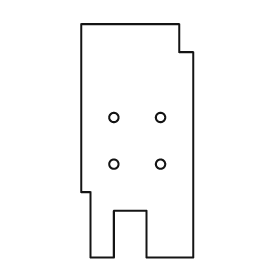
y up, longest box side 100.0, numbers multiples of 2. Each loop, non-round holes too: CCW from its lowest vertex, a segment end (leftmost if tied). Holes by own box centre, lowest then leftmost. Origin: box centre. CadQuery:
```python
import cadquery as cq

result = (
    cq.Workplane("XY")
    .moveTo(-20.0, -50.0)
    .lineTo(-10.0, -50.0)
    .lineTo(-10.0, -30.0)
    .lineTo(4.0, -30.0)
    .lineTo(4.0, -50.0)
    .lineTo(24.0, -50.0)
    .lineTo(24.0, 38.0)
    .lineTo(18.0, 38.0)
    .lineTo(18.0, 50.0)
    .lineTo(-24.0, 50.0)
    .lineTo(-24.0, -22.0)
    .lineTo(-20.0, -22.0)
    .close()
    .moveTo(-10.0, -10.0)
    .circle(2.0)
    .moveTo(10.0, -10.0)
    .circle(2.0)
    .moveTo(-10.0, 10.0)
    .circle(2.0)
    .moveTo(10.0, 10.0)
    .circle(2.0)
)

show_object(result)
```